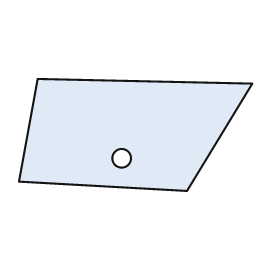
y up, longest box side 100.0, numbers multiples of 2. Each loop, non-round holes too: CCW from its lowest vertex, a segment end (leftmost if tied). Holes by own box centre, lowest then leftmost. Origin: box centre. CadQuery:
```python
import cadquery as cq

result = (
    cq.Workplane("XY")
    .moveTo(22.0, -24.0)
    .lineTo(50.0, 22.0)
    .lineTo(-42.0, 24.0)
    .lineTo(-50.0, -20.0)
    .close()
    .moveTo(-6.0, -10.0)
    .circle(4.0)
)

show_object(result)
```